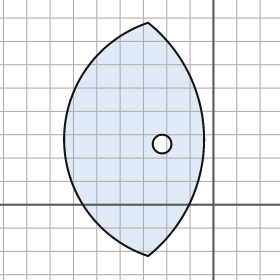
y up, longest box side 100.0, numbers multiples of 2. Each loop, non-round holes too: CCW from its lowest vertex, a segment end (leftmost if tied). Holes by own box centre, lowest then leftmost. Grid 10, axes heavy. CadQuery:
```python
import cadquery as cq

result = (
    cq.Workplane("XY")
    .moveTo(-28.0, -22.0)
    .threePointArc((-4.0, 28.0), (-28.0, 78.0))
    .threePointArc((-64.0, 28.0), (-28.0, -22.0))
    .close()
    .moveTo(-22.0, 26.0)
    .circle(4.0)
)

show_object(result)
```